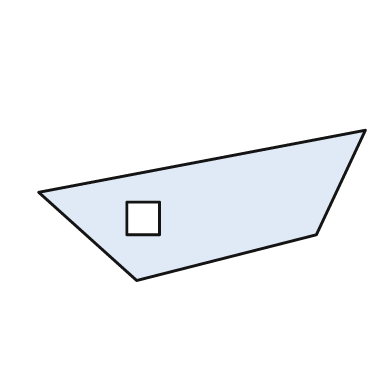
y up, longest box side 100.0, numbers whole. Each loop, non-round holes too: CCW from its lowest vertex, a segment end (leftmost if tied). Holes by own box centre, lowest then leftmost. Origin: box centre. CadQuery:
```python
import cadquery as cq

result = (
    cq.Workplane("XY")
    .moveTo(-20.0, -23.0)
    .lineTo(35.0, -9.0)
    .lineTo(50.0, 23.0)
    .lineTo(-50.0, 4.0)
    .close()
    .moveTo(-23.0, -9.0)
    .lineTo(-13.0, -9.0)
    .lineTo(-13.0, 1.0)
    .lineTo(-23.0, 1.0)
    .close()
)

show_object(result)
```